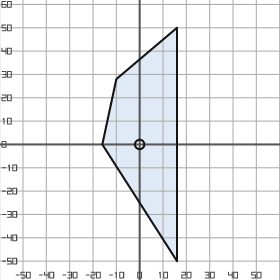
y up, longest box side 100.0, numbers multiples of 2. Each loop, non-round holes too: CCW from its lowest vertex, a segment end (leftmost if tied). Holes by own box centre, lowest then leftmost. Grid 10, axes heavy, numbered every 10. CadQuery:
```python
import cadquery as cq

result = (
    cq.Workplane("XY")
    .moveTo(16.0, -50.0)
    .lineTo(16.0, 50.0)
    .lineTo(-10.0, 28.0)
    .lineTo(-16.0, 0.0)
    .close()
    .moveTo(0.0, 0.0)
    .circle(2.0)
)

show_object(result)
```